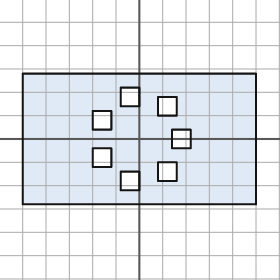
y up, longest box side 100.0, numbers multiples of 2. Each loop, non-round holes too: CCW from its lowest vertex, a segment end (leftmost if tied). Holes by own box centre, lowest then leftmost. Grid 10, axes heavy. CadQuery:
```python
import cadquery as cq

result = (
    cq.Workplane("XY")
    .moveTo(-50.0, -28.0)
    .lineTo(50.0, -28.0)
    .lineTo(50.0, 28.0)
    .lineTo(-50.0, 28.0)
    .close()
    .moveTo(-8.0, -22.0)
    .lineTo(0.0, -22.0)
    .lineTo(0.0, -14.0)
    .lineTo(-8.0, -14.0)
    .close()
    .moveTo(8.0, -18.0)
    .lineTo(16.0, -18.0)
    .lineTo(16.0, -10.0)
    .lineTo(8.0, -10.0)
    .close()
    .moveTo(-20.0, -12.0)
    .lineTo(-12.0, -12.0)
    .lineTo(-12.0, -4.0)
    .lineTo(-20.0, -4.0)
    .close()
    .moveTo(14.0, -4.0)
    .lineTo(22.0, -4.0)
    .lineTo(22.0, 4.0)
    .lineTo(14.0, 4.0)
    .close()
    .moveTo(-20.0, 4.0)
    .lineTo(-12.0, 4.0)
    .lineTo(-12.0, 12.0)
    .lineTo(-20.0, 12.0)
    .close()
    .moveTo(8.0, 10.0)
    .lineTo(16.0, 10.0)
    .lineTo(16.0, 18.0)
    .lineTo(8.0, 18.0)
    .close()
    .moveTo(-8.0, 14.0)
    .lineTo(0.0, 14.0)
    .lineTo(0.0, 22.0)
    .lineTo(-8.0, 22.0)
    .close()
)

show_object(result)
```